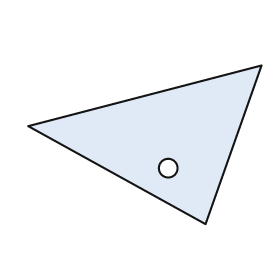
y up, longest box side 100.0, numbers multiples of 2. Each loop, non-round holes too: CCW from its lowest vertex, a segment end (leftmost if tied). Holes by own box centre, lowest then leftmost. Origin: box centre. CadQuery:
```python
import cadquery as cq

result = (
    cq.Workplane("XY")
    .moveTo(26.0, -34.0)
    .lineTo(50.0, 34.0)
    .lineTo(-50.0, 8.0)
    .close()
    .moveTo(10.0, -10.0)
    .circle(4.0)
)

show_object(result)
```